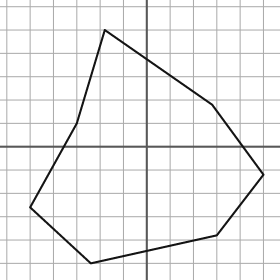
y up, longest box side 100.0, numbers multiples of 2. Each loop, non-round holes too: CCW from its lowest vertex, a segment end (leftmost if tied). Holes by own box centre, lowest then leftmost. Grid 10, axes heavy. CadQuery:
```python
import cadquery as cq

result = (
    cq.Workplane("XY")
    .moveTo(-24.0, -50.0)
    .lineTo(30.0, -38.0)
    .lineTo(50.0, -12.0)
    .lineTo(28.0, 18.0)
    .lineTo(-18.0, 50.0)
    .lineTo(-30.0, 10.0)
    .lineTo(-50.0, -26.0)
    .close()
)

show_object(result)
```